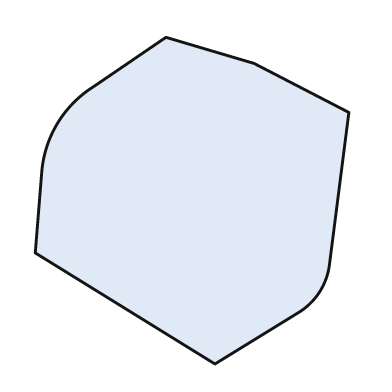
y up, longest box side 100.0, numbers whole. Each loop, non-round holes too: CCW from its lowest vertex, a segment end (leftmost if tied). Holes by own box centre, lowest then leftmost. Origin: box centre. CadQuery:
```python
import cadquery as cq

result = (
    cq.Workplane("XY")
    .moveTo(7.0, -50.0)
    .lineTo(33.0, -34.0)
    .threePointArc((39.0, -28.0), (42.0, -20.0))
    .lineTo(48.0, 27.0)
    .lineTo(19.0, 42.0)
    .lineTo(-8.0, 50.0)
    .lineTo(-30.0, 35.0)
    .threePointArc((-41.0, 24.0), (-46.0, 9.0))
    .lineTo(-48.0, -16.0)
    .close()
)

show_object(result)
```